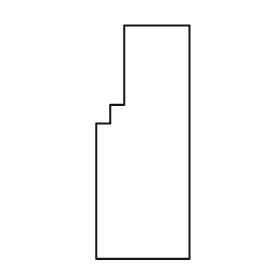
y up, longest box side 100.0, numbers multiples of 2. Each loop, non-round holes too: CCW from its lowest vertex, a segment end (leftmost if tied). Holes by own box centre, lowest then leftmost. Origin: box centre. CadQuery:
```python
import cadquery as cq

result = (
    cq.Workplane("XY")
    .moveTo(-20.0, -50.0)
    .lineTo(20.0, -50.0)
    .lineTo(20.0, 50.0)
    .lineTo(-8.0, 50.0)
    .lineTo(-8.0, 16.0)
    .lineTo(-14.0, 16.0)
    .lineTo(-14.0, 8.0)
    .lineTo(-20.0, 8.0)
    .close()
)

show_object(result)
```